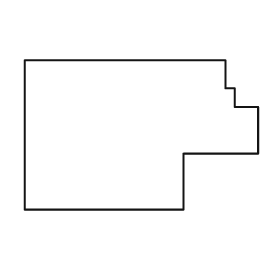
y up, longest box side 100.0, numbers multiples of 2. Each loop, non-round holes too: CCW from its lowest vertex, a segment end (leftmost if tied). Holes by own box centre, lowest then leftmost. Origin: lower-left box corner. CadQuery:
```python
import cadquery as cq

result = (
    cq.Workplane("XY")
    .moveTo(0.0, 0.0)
    .lineTo(68.0, 0.0)
    .lineTo(68.0, 24.0)
    .lineTo(100.0, 24.0)
    .lineTo(100.0, 44.0)
    .lineTo(90.0, 44.0)
    .lineTo(90.0, 52.0)
    .lineTo(86.0, 52.0)
    .lineTo(86.0, 64.0)
    .lineTo(0.0, 64.0)
    .close()
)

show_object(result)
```